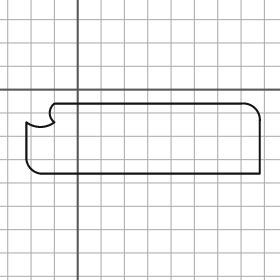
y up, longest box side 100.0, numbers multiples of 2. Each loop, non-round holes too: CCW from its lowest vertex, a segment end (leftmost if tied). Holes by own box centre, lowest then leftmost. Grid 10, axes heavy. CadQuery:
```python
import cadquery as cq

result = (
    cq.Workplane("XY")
    .moveTo(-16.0, -36.0)
    .lineTo(78.0, -36.0)
    .lineTo(78.0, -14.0)
    .threePointArc((76.0, -8.0), (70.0, -6.0))
    .lineTo(-10.0, -6.0)
    .threePointArc((-12.0, -10.0), (-10.0, -14.0))
    .threePointArc((-16.0, -16.0), (-22.0, -14.0))
    .lineTo(-22.0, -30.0)
    .threePointArc((-20.0, -34.0), (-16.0, -36.0))
    .close()
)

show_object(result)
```